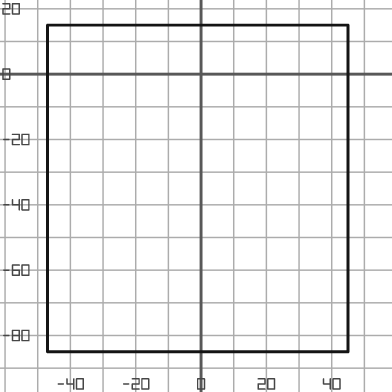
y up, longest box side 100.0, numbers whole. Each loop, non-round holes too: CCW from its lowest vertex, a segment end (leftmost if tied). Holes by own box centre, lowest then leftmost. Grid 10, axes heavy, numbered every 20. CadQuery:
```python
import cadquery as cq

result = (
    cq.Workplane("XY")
    .moveTo(-47.0, -85.0)
    .lineTo(45.0, -85.0)
    .lineTo(45.0, 15.0)
    .lineTo(-47.0, 15.0)
    .close()
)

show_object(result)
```